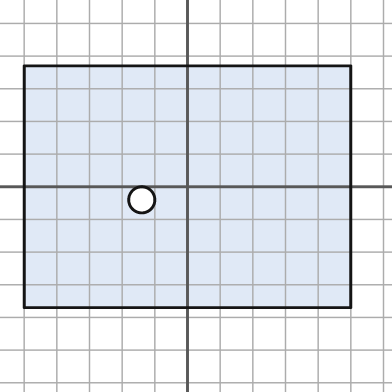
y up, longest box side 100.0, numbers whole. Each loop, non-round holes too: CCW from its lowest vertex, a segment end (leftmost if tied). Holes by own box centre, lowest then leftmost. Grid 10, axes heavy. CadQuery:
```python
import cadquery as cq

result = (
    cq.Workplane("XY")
    .moveTo(-50.0, -37.0)
    .lineTo(50.0, -37.0)
    .lineTo(50.0, 37.0)
    .lineTo(-50.0, 37.0)
    .close()
    .moveTo(-14.0, -4.0)
    .circle(4.0)
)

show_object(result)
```